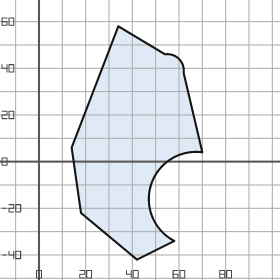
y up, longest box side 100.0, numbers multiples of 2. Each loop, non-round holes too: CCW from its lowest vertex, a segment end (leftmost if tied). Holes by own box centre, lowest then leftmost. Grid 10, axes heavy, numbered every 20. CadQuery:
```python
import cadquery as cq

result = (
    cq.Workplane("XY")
    .moveTo(42.0, -42.0)
    .lineTo(58.0, -34.0)
    .threePointArc((48.0, -10.0), (70.0, 4.0))
    .lineTo(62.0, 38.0)
    .threePointArc((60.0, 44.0), (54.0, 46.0))
    .lineTo(34.0, 58.0)
    .lineTo(14.0, 6.0)
    .lineTo(18.0, -22.0)
    .close()
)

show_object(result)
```